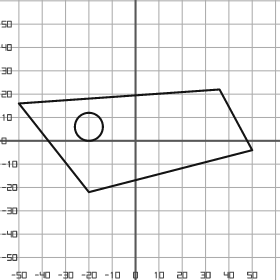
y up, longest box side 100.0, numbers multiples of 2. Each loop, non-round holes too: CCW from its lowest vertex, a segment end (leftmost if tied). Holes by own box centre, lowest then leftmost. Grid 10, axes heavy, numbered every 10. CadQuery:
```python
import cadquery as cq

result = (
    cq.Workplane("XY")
    .moveTo(-20.0, -22.0)
    .lineTo(50.0, -4.0)
    .lineTo(36.0, 22.0)
    .lineTo(-50.0, 16.0)
    .close()
    .moveTo(-20.0, 6.0)
    .circle(6.0)
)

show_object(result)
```